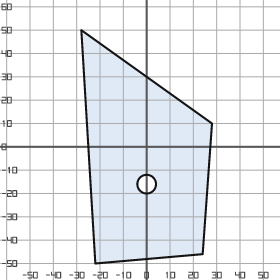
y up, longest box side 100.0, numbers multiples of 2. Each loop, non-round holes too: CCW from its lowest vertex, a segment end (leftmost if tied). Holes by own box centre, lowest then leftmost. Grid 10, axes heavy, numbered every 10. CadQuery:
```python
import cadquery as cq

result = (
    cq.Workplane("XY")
    .moveTo(-22.0, -50.0)
    .lineTo(24.0, -46.0)
    .lineTo(28.0, 10.0)
    .lineTo(-28.0, 50.0)
    .close()
    .moveTo(0.0, -16.0)
    .circle(4.0)
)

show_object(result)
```